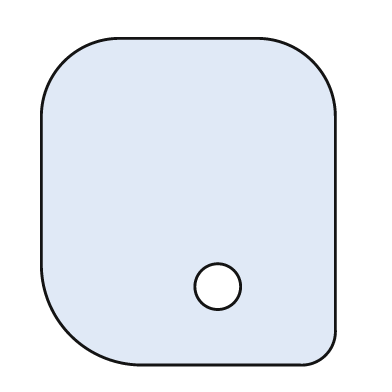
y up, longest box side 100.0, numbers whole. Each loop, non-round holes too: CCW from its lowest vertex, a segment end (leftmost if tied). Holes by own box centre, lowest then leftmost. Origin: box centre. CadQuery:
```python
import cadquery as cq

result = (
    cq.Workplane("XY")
    .moveTo(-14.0, -50.0)
    .lineTo(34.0, -50.0)
    .threePointArc((42.0, -47.0), (45.0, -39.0))
    .lineTo(45.0, 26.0)
    .threePointArc((38.0, 43.0), (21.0, 50.0))
    .lineTo(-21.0, 50.0)
    .threePointArc((-38.0, 43.0), (-45.0, 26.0))
    .lineTo(-45.0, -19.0)
    .threePointArc((-36.0, -41.0), (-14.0, -50.0))
    .close()
    .moveTo(9.0, -26.0)
    .circle(7.0)
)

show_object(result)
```